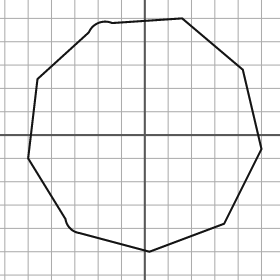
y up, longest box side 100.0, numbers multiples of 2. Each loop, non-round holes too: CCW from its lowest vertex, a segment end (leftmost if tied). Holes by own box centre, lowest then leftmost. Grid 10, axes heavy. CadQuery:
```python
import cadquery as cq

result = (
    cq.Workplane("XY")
    .moveTo(2.0, -50.0)
    .lineTo(34.0, -38.0)
    .lineTo(50.0, -6.0)
    .lineTo(42.0, 28.0)
    .lineTo(16.0, 50.0)
    .lineTo(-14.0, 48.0)
    .threePointArc((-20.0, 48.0), (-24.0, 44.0))
    .lineTo(-46.0, 24.0)
    .lineTo(-50.0, -10.0)
    .lineTo(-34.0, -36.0)
    .threePointArc((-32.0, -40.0), (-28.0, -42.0))
    .close()
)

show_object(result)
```